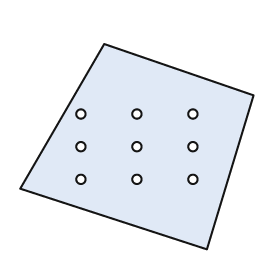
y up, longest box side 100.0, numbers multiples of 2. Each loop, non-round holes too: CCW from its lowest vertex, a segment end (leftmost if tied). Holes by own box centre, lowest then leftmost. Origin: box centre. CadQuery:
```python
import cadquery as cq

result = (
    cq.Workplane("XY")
    .moveTo(30.0, -44.0)
    .lineTo(50.0, 22.0)
    .lineTo(-14.0, 44.0)
    .lineTo(-50.0, -18.0)
    .close()
    .moveTo(-24.0, -14.0)
    .circle(2.0)
    .moveTo(0.0, -14.0)
    .circle(2.0)
    .moveTo(24.0, -14.0)
    .circle(2.0)
    .moveTo(-24.0, 0.0)
    .circle(2.0)
    .moveTo(0.0, 0.0)
    .circle(2.0)
    .moveTo(24.0, 0.0)
    .circle(2.0)
    .moveTo(-24.0, 14.0)
    .circle(2.0)
    .moveTo(0.0, 14.0)
    .circle(2.0)
    .moveTo(24.0, 14.0)
    .circle(2.0)
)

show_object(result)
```